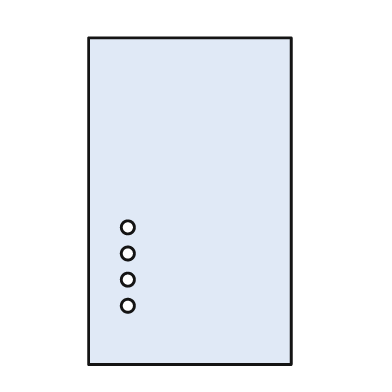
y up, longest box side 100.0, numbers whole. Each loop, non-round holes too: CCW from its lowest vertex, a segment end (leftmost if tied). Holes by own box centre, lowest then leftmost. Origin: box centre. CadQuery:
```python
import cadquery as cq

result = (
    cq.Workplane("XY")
    .moveTo(-31.0, -50.0)
    .lineTo(31.0, -50.0)
    .lineTo(31.0, 50.0)
    .lineTo(-31.0, 50.0)
    .close()
    .moveTo(-19.0, -32.0)
    .circle(2.0)
    .moveTo(-19.0, -24.0)
    .circle(2.0)
    .moveTo(-19.0, -16.0)
    .circle(2.0)
    .moveTo(-19.0, -8.0)
    .circle(2.0)
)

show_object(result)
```